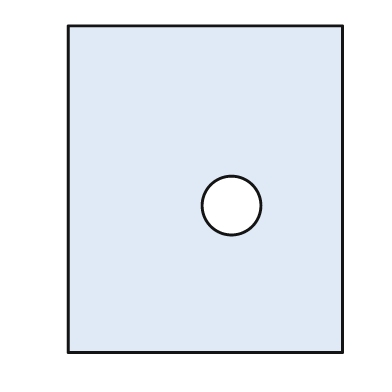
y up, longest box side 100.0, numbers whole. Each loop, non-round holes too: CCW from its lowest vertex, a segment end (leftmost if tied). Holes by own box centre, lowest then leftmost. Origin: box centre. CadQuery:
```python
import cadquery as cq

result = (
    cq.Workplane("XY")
    .moveTo(-42.0, -50.0)
    .lineTo(42.0, -50.0)
    .lineTo(42.0, 50.0)
    .lineTo(-42.0, 50.0)
    .close()
    .moveTo(8.0, -5.0)
    .circle(9.0)
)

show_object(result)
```